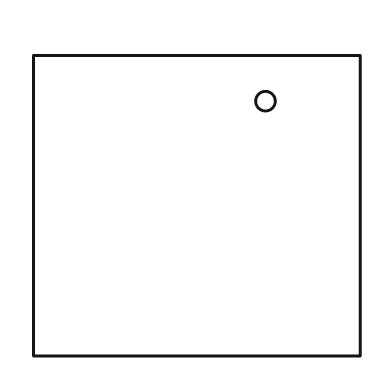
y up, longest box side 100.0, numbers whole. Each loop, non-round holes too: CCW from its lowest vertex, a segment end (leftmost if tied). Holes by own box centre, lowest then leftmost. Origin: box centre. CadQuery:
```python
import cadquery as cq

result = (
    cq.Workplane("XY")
    .moveTo(-50.0, -46.0)
    .lineTo(50.0, -46.0)
    .lineTo(50.0, 46.0)
    .lineTo(-50.0, 46.0)
    .close()
    .moveTo(21.0, 32.0)
    .circle(3.0)
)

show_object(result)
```